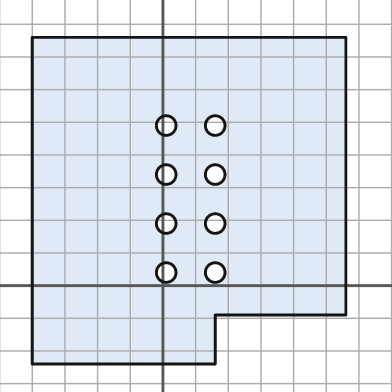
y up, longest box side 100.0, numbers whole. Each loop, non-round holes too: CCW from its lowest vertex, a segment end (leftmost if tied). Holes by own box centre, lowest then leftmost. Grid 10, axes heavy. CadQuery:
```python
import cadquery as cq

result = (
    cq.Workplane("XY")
    .moveTo(-40.0, -24.0)
    .lineTo(16.0, -24.0)
    .lineTo(16.0, -9.0)
    .lineTo(56.0, -9.0)
    .lineTo(56.0, 76.0)
    .lineTo(-40.0, 76.0)
    .close()
    .moveTo(1.0, 4.0)
    .circle(3.0)
    .moveTo(16.0, 4.0)
    .circle(3.0)
    .moveTo(1.0, 19.0)
    .circle(3.0)
    .moveTo(16.0, 19.0)
    .circle(3.0)
    .moveTo(1.0, 34.0)
    .circle(3.0)
    .moveTo(16.0, 34.0)
    .circle(3.0)
    .moveTo(1.0, 49.0)
    .circle(3.0)
    .moveTo(16.0, 49.0)
    .circle(3.0)
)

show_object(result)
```